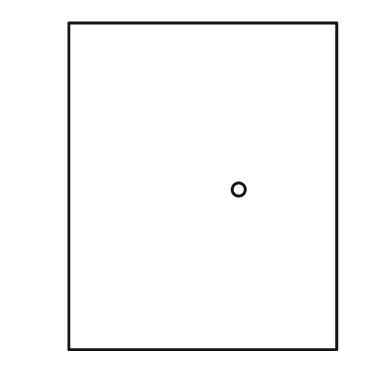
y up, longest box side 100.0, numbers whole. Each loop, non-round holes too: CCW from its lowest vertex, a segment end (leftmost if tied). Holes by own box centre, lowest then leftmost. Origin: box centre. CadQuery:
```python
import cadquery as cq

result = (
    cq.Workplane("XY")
    .moveTo(-41.0, -50.0)
    .lineTo(41.0, -50.0)
    .lineTo(41.0, 50.0)
    .lineTo(-41.0, 50.0)
    .close()
    .moveTo(11.0, -1.0)
    .circle(2.0)
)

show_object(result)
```